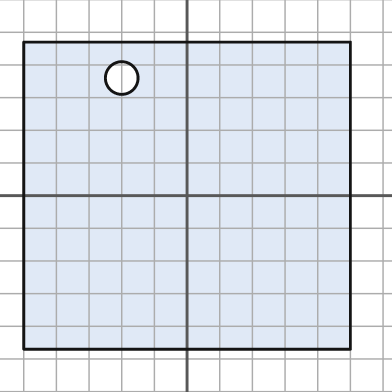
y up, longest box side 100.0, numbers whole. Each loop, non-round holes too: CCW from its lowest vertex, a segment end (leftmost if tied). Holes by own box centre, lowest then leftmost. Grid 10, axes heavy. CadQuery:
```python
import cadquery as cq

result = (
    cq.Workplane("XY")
    .moveTo(-50.0, -47.0)
    .lineTo(50.0, -47.0)
    .lineTo(50.0, 47.0)
    .lineTo(-50.0, 47.0)
    .close()
    .moveTo(-20.0, 36.0)
    .circle(5.0)
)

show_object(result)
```